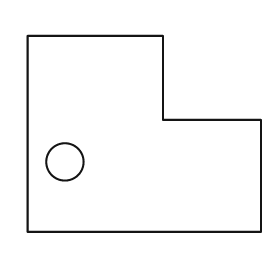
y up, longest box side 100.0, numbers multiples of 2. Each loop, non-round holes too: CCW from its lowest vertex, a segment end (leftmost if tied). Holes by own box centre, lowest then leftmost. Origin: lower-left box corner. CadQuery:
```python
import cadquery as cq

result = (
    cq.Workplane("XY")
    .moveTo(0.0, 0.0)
    .lineTo(100.0, 0.0)
    .lineTo(100.0, 48.0)
    .lineTo(58.0, 48.0)
    .lineTo(58.0, 84.0)
    .lineTo(0.0, 84.0)
    .close()
    .moveTo(16.0, 30.0)
    .circle(8.0)
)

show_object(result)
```